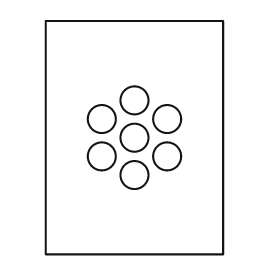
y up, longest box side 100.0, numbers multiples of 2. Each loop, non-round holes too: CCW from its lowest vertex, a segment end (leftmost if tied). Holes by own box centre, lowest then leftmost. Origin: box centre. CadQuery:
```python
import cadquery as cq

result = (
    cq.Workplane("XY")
    .moveTo(-38.0, -50.0)
    .lineTo(38.0, -50.0)
    .lineTo(38.0, 50.0)
    .lineTo(-38.0, 50.0)
    .close()
    .moveTo(0.0, -16.0)
    .circle(6.0)
    .moveTo(-14.0, -8.0)
    .circle(6.0)
    .moveTo(14.0, -8.0)
    .circle(6.0)
    .moveTo(0.0, 0.0)
    .circle(6.0)
    .moveTo(-14.0, 8.0)
    .circle(6.0)
    .moveTo(14.0, 8.0)
    .circle(6.0)
    .moveTo(0.0, 16.0)
    .circle(6.0)
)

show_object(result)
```